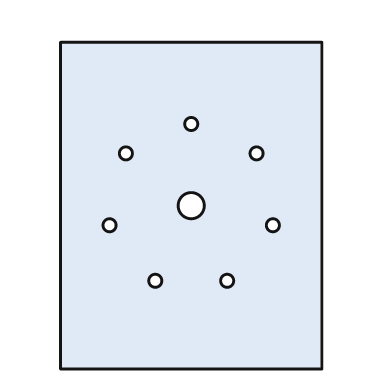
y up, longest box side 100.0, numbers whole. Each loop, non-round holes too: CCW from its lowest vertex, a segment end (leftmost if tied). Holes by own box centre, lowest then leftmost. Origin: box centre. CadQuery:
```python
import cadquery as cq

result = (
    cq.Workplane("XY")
    .moveTo(-40.0, -50.0)
    .lineTo(40.0, -50.0)
    .lineTo(40.0, 50.0)
    .lineTo(-40.0, 50.0)
    .close()
    .moveTo(-11.0, -23.0)
    .circle(2.0)
    .moveTo(11.0, -23.0)
    .circle(2.0)
    .moveTo(-25.0, -6.0)
    .circle(2.0)
    .moveTo(25.0, -6.0)
    .circle(2.0)
    .moveTo(0.0, 0.0)
    .circle(4.0)
    .moveTo(-20.0, 16.0)
    .circle(2.0)
    .moveTo(20.0, 16.0)
    .circle(2.0)
    .moveTo(0.0, 25.0)
    .circle(2.0)
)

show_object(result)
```